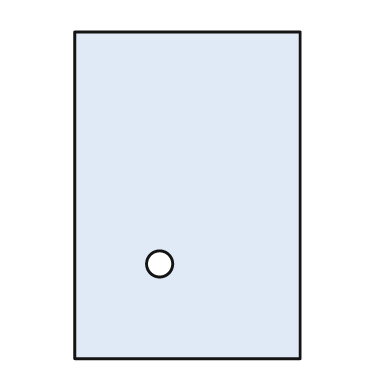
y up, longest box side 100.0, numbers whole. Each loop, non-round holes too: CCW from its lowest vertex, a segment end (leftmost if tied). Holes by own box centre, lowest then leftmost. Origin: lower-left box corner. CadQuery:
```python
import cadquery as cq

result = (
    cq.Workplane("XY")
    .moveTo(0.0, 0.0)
    .lineTo(69.0, 0.0)
    .lineTo(69.0, 100.0)
    .lineTo(0.0, 100.0)
    .close()
    .moveTo(26.0, 29.0)
    .circle(4.0)
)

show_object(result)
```